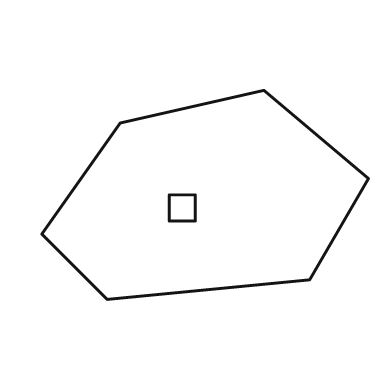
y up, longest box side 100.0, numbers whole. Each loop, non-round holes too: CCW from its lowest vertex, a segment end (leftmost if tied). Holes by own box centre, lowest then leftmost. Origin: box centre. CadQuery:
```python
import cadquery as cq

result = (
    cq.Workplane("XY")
    .moveTo(-30.0, -32.0)
    .lineTo(32.0, -26.0)
    .lineTo(50.0, 5.0)
    .lineTo(18.0, 32.0)
    .lineTo(-26.0, 22.0)
    .lineTo(-50.0, -12.0)
    .close()
    .moveTo(-11.0, -8.0)
    .lineTo(-3.0, -8.0)
    .lineTo(-3.0, 0.0)
    .lineTo(-11.0, 0.0)
    .close()
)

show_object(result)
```